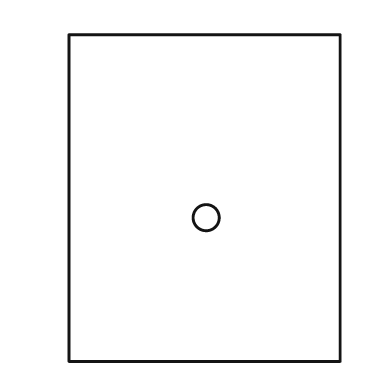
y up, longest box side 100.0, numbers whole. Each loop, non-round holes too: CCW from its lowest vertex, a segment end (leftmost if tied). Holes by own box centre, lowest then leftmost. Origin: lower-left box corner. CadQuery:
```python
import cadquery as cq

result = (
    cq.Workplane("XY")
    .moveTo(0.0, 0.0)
    .lineTo(83.0, 0.0)
    .lineTo(83.0, 100.0)
    .lineTo(0.0, 100.0)
    .close()
    .moveTo(42.0, 44.0)
    .circle(4.0)
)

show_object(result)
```